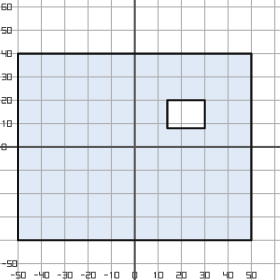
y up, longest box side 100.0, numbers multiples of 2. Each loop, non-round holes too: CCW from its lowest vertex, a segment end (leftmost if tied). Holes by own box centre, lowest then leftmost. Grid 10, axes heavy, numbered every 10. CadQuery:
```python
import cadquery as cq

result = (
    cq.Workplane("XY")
    .moveTo(-50.0, -40.0)
    .lineTo(50.0, -40.0)
    .lineTo(50.0, 40.0)
    .lineTo(-50.0, 40.0)
    .close()
    .moveTo(14.0, 8.0)
    .lineTo(30.0, 8.0)
    .lineTo(30.0, 20.0)
    .lineTo(14.0, 20.0)
    .close()
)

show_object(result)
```